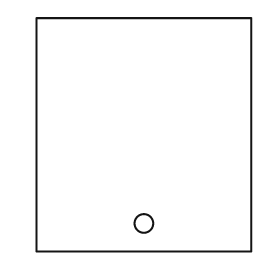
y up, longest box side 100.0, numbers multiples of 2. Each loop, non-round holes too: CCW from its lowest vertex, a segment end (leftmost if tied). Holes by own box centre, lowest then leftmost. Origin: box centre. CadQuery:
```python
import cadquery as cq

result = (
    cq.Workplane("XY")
    .moveTo(-46.0, -50.0)
    .lineTo(46.0, -50.0)
    .lineTo(46.0, 50.0)
    .lineTo(-46.0, 50.0)
    .close()
    .moveTo(0.0, -38.0)
    .circle(4.0)
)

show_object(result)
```